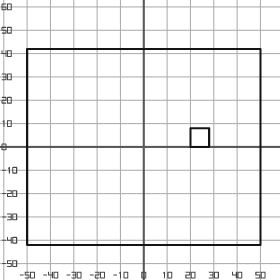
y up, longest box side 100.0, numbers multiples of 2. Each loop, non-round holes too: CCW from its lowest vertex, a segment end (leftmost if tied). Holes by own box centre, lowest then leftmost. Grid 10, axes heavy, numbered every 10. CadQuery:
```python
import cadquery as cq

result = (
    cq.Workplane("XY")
    .moveTo(-50.0, -42.0)
    .lineTo(50.0, -42.0)
    .lineTo(50.0, 42.0)
    .lineTo(-50.0, 42.0)
    .close()
    .moveTo(20.0, 0.0)
    .lineTo(28.0, 0.0)
    .lineTo(28.0, 8.0)
    .lineTo(20.0, 8.0)
    .close()
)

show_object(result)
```